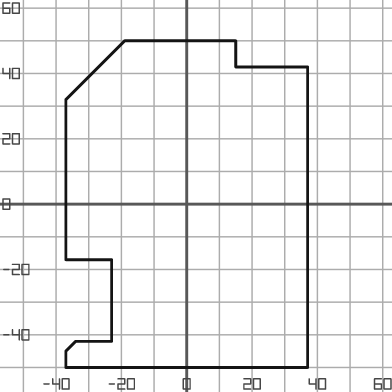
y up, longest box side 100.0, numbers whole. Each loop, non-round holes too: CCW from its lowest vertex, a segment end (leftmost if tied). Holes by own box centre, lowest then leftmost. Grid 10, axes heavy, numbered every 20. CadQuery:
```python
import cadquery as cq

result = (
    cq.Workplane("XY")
    .moveTo(-37.0, -50.0)
    .lineTo(37.0, -50.0)
    .lineTo(37.0, 42.0)
    .lineTo(15.0, 42.0)
    .lineTo(15.0, 50.0)
    .lineTo(-19.0, 50.0)
    .lineTo(-37.0, 32.0)
    .lineTo(-37.0, -17.0)
    .lineTo(-23.0, -17.0)
    .lineTo(-23.0, -42.0)
    .lineTo(-34.0, -42.0)
    .lineTo(-37.0, -45.0)
    .close()
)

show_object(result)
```